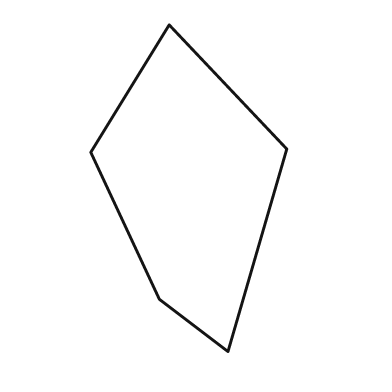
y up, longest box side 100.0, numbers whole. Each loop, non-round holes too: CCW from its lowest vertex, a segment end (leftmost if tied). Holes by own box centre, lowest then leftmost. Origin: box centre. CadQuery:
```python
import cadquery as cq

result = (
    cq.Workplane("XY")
    .moveTo(12.0, -50.0)
    .lineTo(30.0, 12.0)
    .lineTo(-6.0, 50.0)
    .lineTo(-30.0, 11.0)
    .lineTo(-9.0, -34.0)
    .close()
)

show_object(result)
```